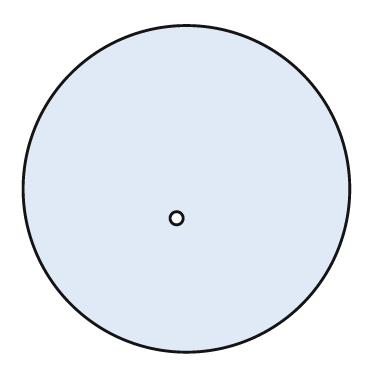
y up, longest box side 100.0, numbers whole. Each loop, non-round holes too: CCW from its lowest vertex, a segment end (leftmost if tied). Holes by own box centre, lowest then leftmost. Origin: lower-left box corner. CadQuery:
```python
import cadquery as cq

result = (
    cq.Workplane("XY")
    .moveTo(50.0, 50.0)
    .circle(50.0)
    .moveTo(47.0, 41.0)
    .circle(2.0)
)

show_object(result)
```